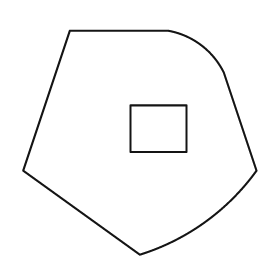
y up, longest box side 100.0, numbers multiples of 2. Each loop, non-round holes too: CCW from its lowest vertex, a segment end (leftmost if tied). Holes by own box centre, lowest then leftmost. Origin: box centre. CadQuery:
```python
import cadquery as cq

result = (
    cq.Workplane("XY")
    .moveTo(0.0, -48.0)
    .threePointArc((28.0, -34.0), (50.0, -12.0))
    .lineTo(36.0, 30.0)
    .threePointArc((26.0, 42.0), (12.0, 48.0))
    .lineTo(-30.0, 48.0)
    .lineTo(-50.0, -12.0)
    .close()
    .moveTo(-4.0, -4.0)
    .lineTo(20.0, -4.0)
    .lineTo(20.0, 16.0)
    .lineTo(-4.0, 16.0)
    .close()
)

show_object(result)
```